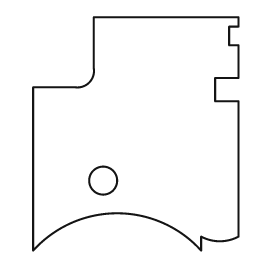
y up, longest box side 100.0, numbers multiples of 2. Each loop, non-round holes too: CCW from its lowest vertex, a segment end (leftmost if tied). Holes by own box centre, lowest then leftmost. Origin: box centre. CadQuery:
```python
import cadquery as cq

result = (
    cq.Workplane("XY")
    .moveTo(-44.0, -50.0)
    .threePointArc((-8.0, -34.0), (28.0, -50.0))
    .lineTo(28.0, -44.0)
    .threePointArc((36.0, -46.0), (44.0, -44.0))
    .lineTo(44.0, 14.0)
    .lineTo(34.0, 14.0)
    .lineTo(34.0, 24.0)
    .lineTo(44.0, 24.0)
    .lineTo(44.0, 38.0)
    .lineTo(40.0, 38.0)
    .lineTo(40.0, 46.0)
    .lineTo(44.0, 46.0)
    .lineTo(44.0, 50.0)
    .lineTo(-18.0, 50.0)
    .lineTo(-18.0, 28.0)
    .threePointArc((-20.0, 22.0), (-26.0, 20.0))
    .lineTo(-44.0, 20.0)
    .close()
    .moveTo(-14.0, -20.0)
    .circle(6.0)
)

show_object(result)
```